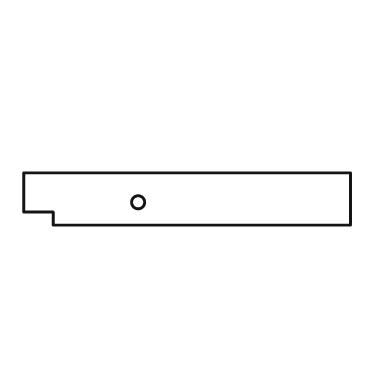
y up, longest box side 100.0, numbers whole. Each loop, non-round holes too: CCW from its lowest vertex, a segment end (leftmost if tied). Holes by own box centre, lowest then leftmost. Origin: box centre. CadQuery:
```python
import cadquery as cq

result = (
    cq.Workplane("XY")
    .moveTo(-41.0, -8.0)
    .lineTo(50.0, -8.0)
    .lineTo(50.0, 8.0)
    .lineTo(-50.0, 8.0)
    .lineTo(-50.0, -4.0)
    .lineTo(-41.0, -4.0)
    .close()
    .moveTo(-15.0, -1.0)
    .circle(2.0)
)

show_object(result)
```